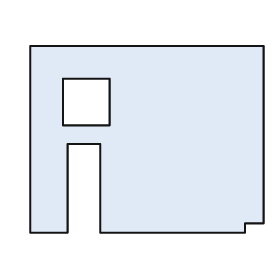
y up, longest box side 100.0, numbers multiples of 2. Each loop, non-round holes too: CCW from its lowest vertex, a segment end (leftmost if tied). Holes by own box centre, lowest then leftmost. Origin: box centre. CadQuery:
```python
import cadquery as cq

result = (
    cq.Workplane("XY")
    .moveTo(-50.0, -40.0)
    .lineTo(-34.0, -40.0)
    .lineTo(-34.0, -2.0)
    .lineTo(-20.0, -2.0)
    .lineTo(-20.0, -40.0)
    .lineTo(42.0, -40.0)
    .lineTo(42.0, -36.0)
    .lineTo(50.0, -36.0)
    .lineTo(50.0, 40.0)
    .lineTo(-50.0, 40.0)
    .close()
    .moveTo(-36.0, 6.0)
    .lineTo(-16.0, 6.0)
    .lineTo(-16.0, 26.0)
    .lineTo(-36.0, 26.0)
    .close()
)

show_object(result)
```